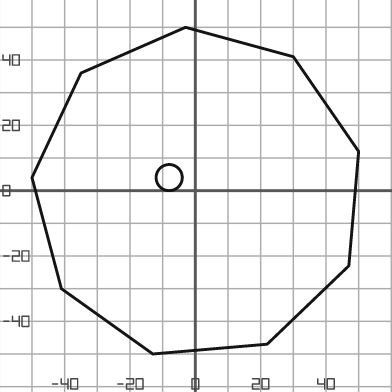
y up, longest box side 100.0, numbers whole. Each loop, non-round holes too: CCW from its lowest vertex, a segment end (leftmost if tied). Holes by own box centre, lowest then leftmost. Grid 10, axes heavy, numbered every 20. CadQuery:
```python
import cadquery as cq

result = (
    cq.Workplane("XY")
    .moveTo(-13.0, -50.0)
    .lineTo(22.0, -47.0)
    .lineTo(47.0, -23.0)
    .lineTo(50.0, 12.0)
    .lineTo(30.0, 41.0)
    .lineTo(-3.0, 50.0)
    .lineTo(-35.0, 36.0)
    .lineTo(-50.0, 4.0)
    .lineTo(-41.0, -30.0)
    .close()
    .moveTo(-8.0, 4.0)
    .circle(4.0)
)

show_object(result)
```